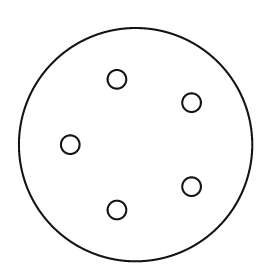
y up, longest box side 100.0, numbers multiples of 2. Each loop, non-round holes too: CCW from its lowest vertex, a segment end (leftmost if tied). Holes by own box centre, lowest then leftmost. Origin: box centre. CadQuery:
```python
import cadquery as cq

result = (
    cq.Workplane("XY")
    .moveTo(0.0, 0.0)
    .circle(50.0)
    .moveTo(-8.0, -28.0)
    .circle(4.0)
    .moveTo(24.0, -18.0)
    .circle(4.0)
    .moveTo(-28.0, 0.0)
    .circle(4.0)
    .moveTo(24.0, 18.0)
    .circle(4.0)
    .moveTo(-8.0, 28.0)
    .circle(4.0)
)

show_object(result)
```